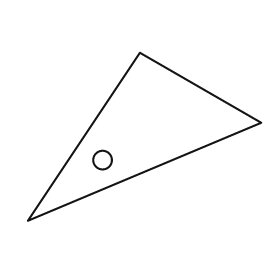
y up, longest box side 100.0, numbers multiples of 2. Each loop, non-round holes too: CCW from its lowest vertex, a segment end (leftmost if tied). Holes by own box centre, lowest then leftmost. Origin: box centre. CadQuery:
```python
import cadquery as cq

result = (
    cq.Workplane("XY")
    .moveTo(-50.0, -36.0)
    .lineTo(50.0, 6.0)
    .lineTo(-2.0, 36.0)
    .close()
    .moveTo(-18.0, -10.0)
    .circle(4.0)
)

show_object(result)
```